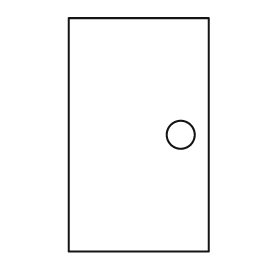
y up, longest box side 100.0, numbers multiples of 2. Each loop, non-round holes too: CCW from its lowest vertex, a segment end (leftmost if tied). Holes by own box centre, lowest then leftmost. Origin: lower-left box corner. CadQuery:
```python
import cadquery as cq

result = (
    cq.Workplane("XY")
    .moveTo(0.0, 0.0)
    .lineTo(60.0, 0.0)
    .lineTo(60.0, 100.0)
    .lineTo(0.0, 100.0)
    .close()
    .moveTo(48.0, 50.0)
    .circle(6.0)
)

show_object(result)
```